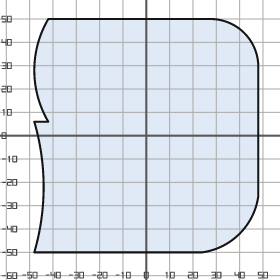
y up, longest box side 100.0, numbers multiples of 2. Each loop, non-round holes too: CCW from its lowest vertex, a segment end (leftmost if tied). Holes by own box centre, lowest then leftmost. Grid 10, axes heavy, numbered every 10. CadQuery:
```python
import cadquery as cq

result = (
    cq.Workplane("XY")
    .moveTo(-48.0, -50.0)
    .lineTo(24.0, -50.0)
    .threePointArc((40.0, -42.0), (48.0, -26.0))
    .lineTo(48.0, 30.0)
    .threePointArc((42.0, 44.0), (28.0, 50.0))
    .lineTo(-42.0, 50.0)
    .threePointArc((-48.0, 28.0), (-42.0, 6.0))
    .lineTo(-48.0, 6.0)
    .threePointArc((-44.0, -22.0), (-48.0, -50.0))
    .close()
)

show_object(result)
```